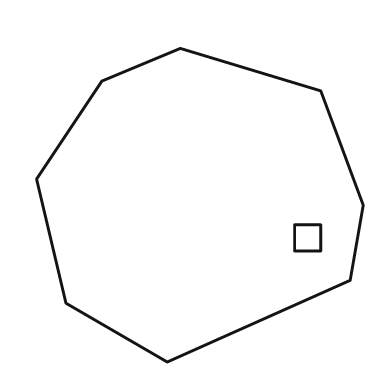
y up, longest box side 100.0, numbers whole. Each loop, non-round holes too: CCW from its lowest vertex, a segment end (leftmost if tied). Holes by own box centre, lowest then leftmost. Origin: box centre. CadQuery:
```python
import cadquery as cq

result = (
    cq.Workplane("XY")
    .moveTo(-10.0, -48.0)
    .lineTo(46.0, -23.0)
    .lineTo(50.0, 0.0)
    .lineTo(37.0, 35.0)
    .lineTo(-6.0, 48.0)
    .lineTo(-30.0, 38.0)
    .lineTo(-50.0, 8.0)
    .lineTo(-41.0, -30.0)
    .close()
    .moveTo(29.0, -14.0)
    .lineTo(37.0, -14.0)
    .lineTo(37.0, -6.0)
    .lineTo(29.0, -6.0)
    .close()
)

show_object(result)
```